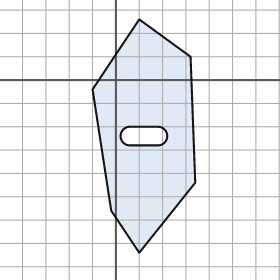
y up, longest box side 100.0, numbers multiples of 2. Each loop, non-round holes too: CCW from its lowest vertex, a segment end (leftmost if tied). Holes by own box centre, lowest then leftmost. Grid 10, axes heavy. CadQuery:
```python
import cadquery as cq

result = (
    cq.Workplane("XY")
    .moveTo(10.0, -74.0)
    .lineTo(34.0, -44.0)
    .lineTo(32.0, 10.0)
    .lineTo(10.0, 26.0)
    .lineTo(-10.0, -4.0)
    .lineTo(-2.0, -56.0)
    .close()
    .moveTo(6.0, -28.0)
    .lineTo(18.0, -28.0)
    .threePointArc((22.0, -24.0), (18.0, -20.0))
    .lineTo(6.0, -20.0)
    .threePointArc((2.0, -24.0), (6.0, -28.0))
    .close()
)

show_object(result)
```